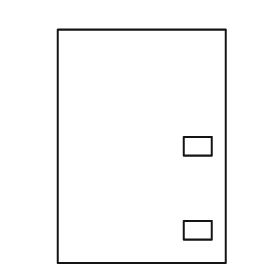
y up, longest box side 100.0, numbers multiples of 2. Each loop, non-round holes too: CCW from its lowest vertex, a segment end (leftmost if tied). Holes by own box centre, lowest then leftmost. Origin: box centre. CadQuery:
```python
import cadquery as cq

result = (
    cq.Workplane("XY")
    .moveTo(-36.0, -50.0)
    .lineTo(36.0, -50.0)
    .lineTo(36.0, 50.0)
    .lineTo(-36.0, 50.0)
    .close()
    .moveTo(18.0, -40.0)
    .lineTo(30.0, -40.0)
    .lineTo(30.0, -32.0)
    .lineTo(18.0, -32.0)
    .close()
    .moveTo(18.0, -4.0)
    .lineTo(30.0, -4.0)
    .lineTo(30.0, 4.0)
    .lineTo(18.0, 4.0)
    .close()
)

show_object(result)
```